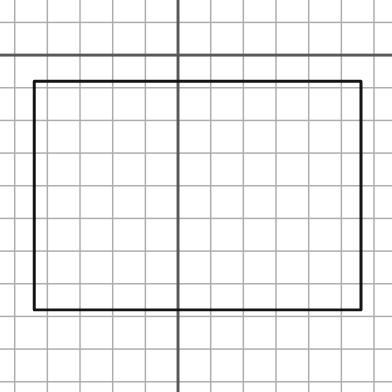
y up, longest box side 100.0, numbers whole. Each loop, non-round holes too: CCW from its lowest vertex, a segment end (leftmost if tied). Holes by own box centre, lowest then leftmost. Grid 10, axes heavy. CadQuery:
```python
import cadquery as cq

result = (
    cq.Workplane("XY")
    .moveTo(-44.0, -78.0)
    .lineTo(56.0, -78.0)
    .lineTo(56.0, -8.0)
    .lineTo(-44.0, -8.0)
    .close()
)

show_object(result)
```